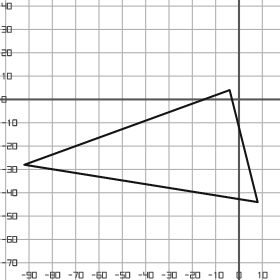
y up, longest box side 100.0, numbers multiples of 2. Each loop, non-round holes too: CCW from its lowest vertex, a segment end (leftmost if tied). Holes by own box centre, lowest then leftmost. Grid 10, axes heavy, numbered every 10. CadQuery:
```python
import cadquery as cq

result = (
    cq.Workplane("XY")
    .moveTo(8.0, -44.0)
    .lineTo(-4.0, 4.0)
    .lineTo(-92.0, -28.0)
    .close()
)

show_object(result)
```